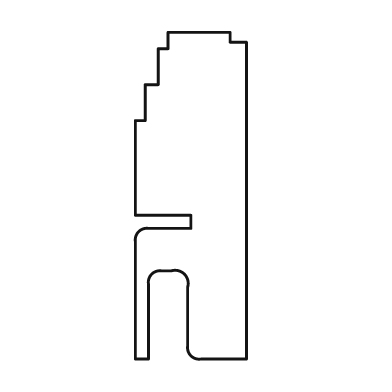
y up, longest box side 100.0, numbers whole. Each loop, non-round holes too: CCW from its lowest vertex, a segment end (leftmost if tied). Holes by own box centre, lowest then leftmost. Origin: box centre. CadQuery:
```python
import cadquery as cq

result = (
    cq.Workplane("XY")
    .moveTo(-17.0, -50.0)
    .lineTo(-13.0, -50.0)
    .lineTo(-13.0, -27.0)
    .threePointArc((-12.0, -24.0), (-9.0, -23.0))
    .lineTo(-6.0, -23.0)
    .threePointArc((-2.0, -24.0), (-1.0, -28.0))
    .lineTo(-1.0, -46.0)
    .threePointArc((0.0, -49.0), (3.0, -50.0))
    .lineTo(17.0, -50.0)
    .lineTo(17.0, 47.0)
    .lineTo(12.0, 47.0)
    .lineTo(12.0, 50.0)
    .lineTo(-7.0, 50.0)
    .lineTo(-7.0, 45.0)
    .lineTo(-10.0, 45.0)
    .lineTo(-10.0, 34.0)
    .lineTo(-14.0, 34.0)
    .lineTo(-14.0, 23.0)
    .lineTo(-17.0, 23.0)
    .lineTo(-17.0, -6.0)
    .lineTo(0.0, -6.0)
    .lineTo(0.0, -10.0)
    .lineTo(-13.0, -10.0)
    .threePointArc((-16.0, -11.0), (-17.0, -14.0))
    .close()
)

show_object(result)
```